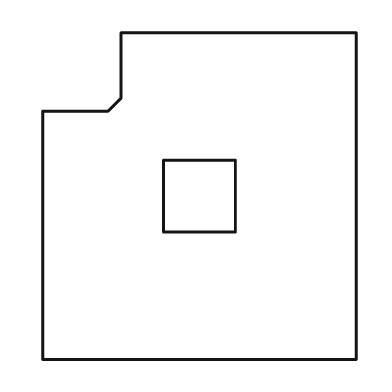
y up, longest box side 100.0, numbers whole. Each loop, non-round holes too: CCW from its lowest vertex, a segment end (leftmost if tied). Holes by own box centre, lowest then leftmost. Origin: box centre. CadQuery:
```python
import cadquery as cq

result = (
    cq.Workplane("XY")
    .moveTo(-48.0, -50.0)
    .lineTo(48.0, -50.0)
    .lineTo(48.0, 50.0)
    .lineTo(-24.0, 50.0)
    .lineTo(-24.0, 30.0)
    .lineTo(-28.0, 26.0)
    .lineTo(-48.0, 26.0)
    .close()
    .moveTo(-11.0, -11.0)
    .lineTo(11.0, -11.0)
    .lineTo(11.0, 11.0)
    .lineTo(-11.0, 11.0)
    .close()
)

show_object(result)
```